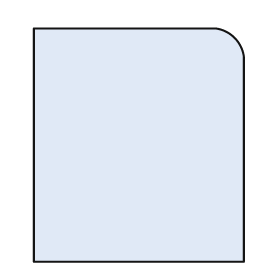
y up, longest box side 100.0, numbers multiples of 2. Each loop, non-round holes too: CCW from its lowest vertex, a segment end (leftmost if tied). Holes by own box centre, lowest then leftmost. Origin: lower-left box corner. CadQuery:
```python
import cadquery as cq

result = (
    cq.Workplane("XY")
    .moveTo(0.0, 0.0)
    .lineTo(90.0, 0.0)
    .lineTo(90.0, 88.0)
    .threePointArc((86.0, 96.0), (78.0, 100.0))
    .lineTo(0.0, 100.0)
    .close()
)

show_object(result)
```